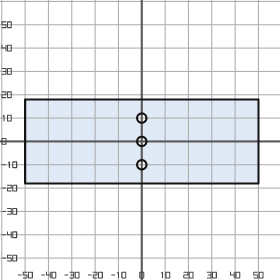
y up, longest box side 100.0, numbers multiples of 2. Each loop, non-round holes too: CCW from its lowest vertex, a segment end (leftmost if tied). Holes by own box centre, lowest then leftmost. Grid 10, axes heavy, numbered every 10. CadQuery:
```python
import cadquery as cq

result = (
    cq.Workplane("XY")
    .moveTo(-50.0, -18.0)
    .lineTo(50.0, -18.0)
    .lineTo(50.0, 18.0)
    .lineTo(-50.0, 18.0)
    .close()
    .moveTo(0.0, -10.0)
    .circle(2.0)
    .moveTo(0.0, 0.0)
    .circle(2.0)
    .moveTo(0.0, 10.0)
    .circle(2.0)
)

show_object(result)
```